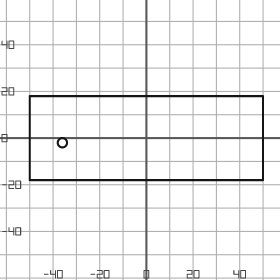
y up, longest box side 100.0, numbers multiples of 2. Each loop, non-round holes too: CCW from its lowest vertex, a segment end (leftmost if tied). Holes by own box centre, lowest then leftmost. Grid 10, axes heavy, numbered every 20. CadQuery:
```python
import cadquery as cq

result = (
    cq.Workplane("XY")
    .moveTo(-50.0, -18.0)
    .lineTo(50.0, -18.0)
    .lineTo(50.0, 18.0)
    .lineTo(-50.0, 18.0)
    .close()
    .moveTo(-36.0, -2.0)
    .circle(2.0)
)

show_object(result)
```